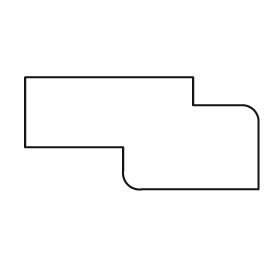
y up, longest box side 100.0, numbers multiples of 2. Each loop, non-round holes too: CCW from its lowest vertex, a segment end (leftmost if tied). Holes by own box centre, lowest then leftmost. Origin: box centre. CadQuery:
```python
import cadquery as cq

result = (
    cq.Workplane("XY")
    .moveTo(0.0, -24.0)
    .lineTo(50.0, -24.0)
    .lineTo(50.0, 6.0)
    .threePointArc((48.0, 10.0), (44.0, 12.0))
    .lineTo(22.0, 12.0)
    .lineTo(22.0, 24.0)
    .lineTo(-50.0, 24.0)
    .lineTo(-50.0, -6.0)
    .lineTo(-8.0, -6.0)
    .lineTo(-8.0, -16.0)
    .threePointArc((-6.0, -22.0), (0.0, -24.0))
    .close()
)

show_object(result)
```